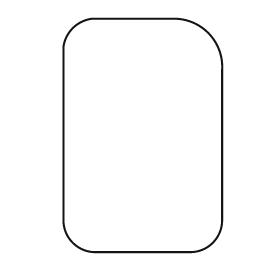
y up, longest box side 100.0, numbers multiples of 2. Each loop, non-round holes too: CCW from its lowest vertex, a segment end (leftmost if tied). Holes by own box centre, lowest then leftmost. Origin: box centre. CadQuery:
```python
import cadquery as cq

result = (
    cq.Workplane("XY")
    .moveTo(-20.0, -50.0)
    .lineTo(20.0, -50.0)
    .threePointArc((30.0, -46.0), (34.0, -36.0))
    .lineTo(34.0, 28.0)
    .threePointArc((28.0, 44.0), (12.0, 50.0))
    .lineTo(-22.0, 50.0)
    .threePointArc((-30.0, 46.0), (-34.0, 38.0))
    .lineTo(-34.0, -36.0)
    .threePointArc((-30.0, -46.0), (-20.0, -50.0))
    .close()
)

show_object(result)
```